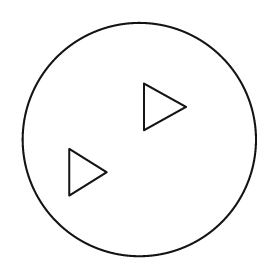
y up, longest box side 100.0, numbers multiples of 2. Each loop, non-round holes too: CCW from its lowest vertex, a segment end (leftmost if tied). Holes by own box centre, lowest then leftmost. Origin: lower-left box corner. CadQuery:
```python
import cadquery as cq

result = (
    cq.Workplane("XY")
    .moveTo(50.0, 50.0)
    .circle(50.0)
    .moveTo(20.0, 26.0)
    .lineTo(36.0, 36.0)
    .lineTo(20.0, 46.0)
    .close()
    .moveTo(52.0, 54.0)
    .lineTo(70.0, 64.0)
    .lineTo(52.0, 74.0)
    .close()
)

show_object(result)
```